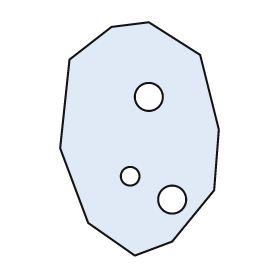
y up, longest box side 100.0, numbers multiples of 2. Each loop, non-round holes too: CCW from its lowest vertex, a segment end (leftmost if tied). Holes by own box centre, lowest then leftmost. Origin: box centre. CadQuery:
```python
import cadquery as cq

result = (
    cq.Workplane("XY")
    .moveTo(-2.0, -50.0)
    .lineTo(14.0, -44.0)
    .lineTo(32.0, -22.0)
    .lineTo(34.0, 4.0)
    .lineTo(26.0, 36.0)
    .lineTo(4.0, 50.0)
    .lineTo(-12.0, 48.0)
    .lineTo(-30.0, 34.0)
    .lineTo(-34.0, -4.0)
    .lineTo(-22.0, -36.0)
    .close()
    .moveTo(14.0, -26.0)
    .circle(6.0)
    .moveTo(-4.0, -16.0)
    .circle(4.0)
    .moveTo(4.0, 18.0)
    .circle(6.0)
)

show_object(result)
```